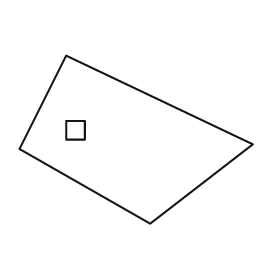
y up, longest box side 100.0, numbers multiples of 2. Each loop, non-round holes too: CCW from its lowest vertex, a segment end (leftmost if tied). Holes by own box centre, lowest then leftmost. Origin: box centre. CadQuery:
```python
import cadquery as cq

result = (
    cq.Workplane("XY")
    .moveTo(6.0, -36.0)
    .lineTo(50.0, -2.0)
    .lineTo(-30.0, 36.0)
    .lineTo(-50.0, -4.0)
    .close()
    .moveTo(-30.0, 0.0)
    .lineTo(-22.0, 0.0)
    .lineTo(-22.0, 8.0)
    .lineTo(-30.0, 8.0)
    .close()
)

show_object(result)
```